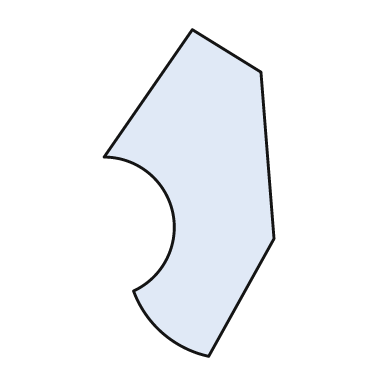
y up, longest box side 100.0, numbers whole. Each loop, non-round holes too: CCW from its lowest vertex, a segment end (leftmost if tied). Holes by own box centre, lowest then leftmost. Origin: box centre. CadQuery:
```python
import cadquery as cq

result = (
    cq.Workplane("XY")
    .moveTo(6.0, -50.0)
    .lineTo(26.0, -14.0)
    .lineTo(22.0, 37.0)
    .lineTo(1.0, 50.0)
    .lineTo(-26.0, 11.0)
    .threePointArc((-5.0, -6.0), (-17.0, -30.0))
    .threePointArc((-8.0, -43.0), (6.0, -50.0))
    .close()
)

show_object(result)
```